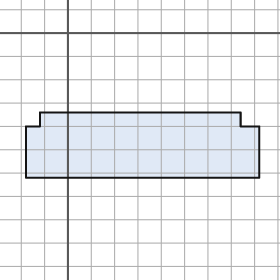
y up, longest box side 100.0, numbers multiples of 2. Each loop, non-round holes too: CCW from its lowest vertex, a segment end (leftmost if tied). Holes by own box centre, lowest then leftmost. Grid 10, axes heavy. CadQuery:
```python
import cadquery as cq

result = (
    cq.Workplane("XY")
    .moveTo(-18.0, -62.0)
    .lineTo(82.0, -62.0)
    .lineTo(82.0, -40.0)
    .lineTo(74.0, -40.0)
    .lineTo(74.0, -34.0)
    .lineTo(-12.0, -34.0)
    .lineTo(-12.0, -40.0)
    .lineTo(-18.0, -40.0)
    .close()
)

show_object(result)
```